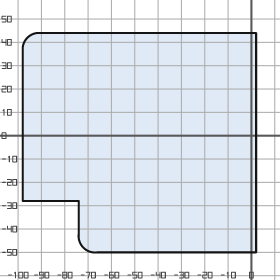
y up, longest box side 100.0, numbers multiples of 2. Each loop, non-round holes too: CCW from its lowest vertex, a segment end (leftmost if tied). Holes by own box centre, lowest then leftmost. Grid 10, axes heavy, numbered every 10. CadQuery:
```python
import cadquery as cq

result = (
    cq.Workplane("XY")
    .moveTo(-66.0, -50.0)
    .lineTo(2.0, -50.0)
    .lineTo(2.0, 44.0)
    .lineTo(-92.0, 44.0)
    .threePointArc((-96.0, 42.0), (-98.0, 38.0))
    .lineTo(-98.0, -28.0)
    .lineTo(-74.0, -28.0)
    .lineTo(-74.0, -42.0)
    .threePointArc((-72.0, -48.0), (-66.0, -50.0))
    .close()
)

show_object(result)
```